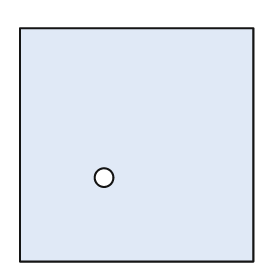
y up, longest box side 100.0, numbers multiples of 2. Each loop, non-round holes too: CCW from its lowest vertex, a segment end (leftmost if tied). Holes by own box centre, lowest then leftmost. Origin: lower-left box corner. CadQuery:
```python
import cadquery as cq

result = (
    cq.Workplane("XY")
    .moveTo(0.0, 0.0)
    .lineTo(100.0, 0.0)
    .lineTo(100.0, 100.0)
    .lineTo(0.0, 100.0)
    .close()
    .moveTo(36.0, 36.0)
    .circle(4.0)
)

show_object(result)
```